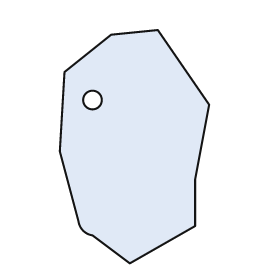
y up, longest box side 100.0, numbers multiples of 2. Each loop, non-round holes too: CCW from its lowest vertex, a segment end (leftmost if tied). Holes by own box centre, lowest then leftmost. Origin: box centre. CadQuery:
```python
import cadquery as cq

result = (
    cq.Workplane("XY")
    .moveTo(-2.0, -50.0)
    .lineTo(26.0, -34.0)
    .lineTo(26.0, -14.0)
    .lineTo(32.0, 18.0)
    .lineTo(10.0, 50.0)
    .lineTo(-10.0, 48.0)
    .lineTo(-30.0, 32.0)
    .lineTo(-32.0, -2.0)
    .lineTo(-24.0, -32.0)
    .threePointArc((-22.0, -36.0), (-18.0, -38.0))
    .close()
    .moveTo(-18.0, 20.0)
    .circle(4.0)
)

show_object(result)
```